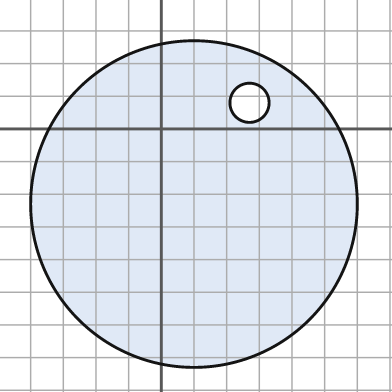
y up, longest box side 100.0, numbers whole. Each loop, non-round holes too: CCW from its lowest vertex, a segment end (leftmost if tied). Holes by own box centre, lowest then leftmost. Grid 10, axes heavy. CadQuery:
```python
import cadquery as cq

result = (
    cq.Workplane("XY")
    .moveTo(10.0, -23.0)
    .circle(50.0)
    .moveTo(27.0, 8.0)
    .circle(6.0)
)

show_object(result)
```